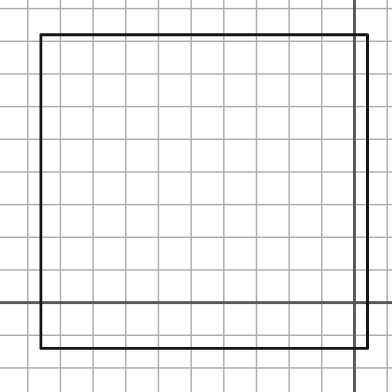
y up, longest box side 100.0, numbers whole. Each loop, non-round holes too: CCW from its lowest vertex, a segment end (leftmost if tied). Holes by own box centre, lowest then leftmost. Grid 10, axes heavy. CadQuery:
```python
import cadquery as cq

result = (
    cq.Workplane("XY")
    .moveTo(-96.0, -14.0)
    .lineTo(4.0, -14.0)
    .lineTo(4.0, 82.0)
    .lineTo(-96.0, 82.0)
    .close()
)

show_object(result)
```